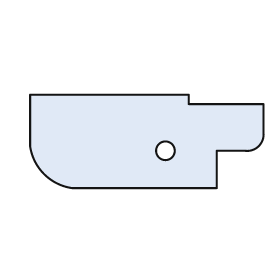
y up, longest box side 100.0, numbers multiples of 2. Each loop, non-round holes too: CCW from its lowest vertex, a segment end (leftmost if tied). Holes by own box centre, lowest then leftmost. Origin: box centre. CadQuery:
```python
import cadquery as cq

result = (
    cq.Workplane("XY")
    .moveTo(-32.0, -20.0)
    .lineTo(30.0, -20.0)
    .lineTo(30.0, -4.0)
    .lineTo(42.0, -4.0)
    .threePointArc((48.0, -2.0), (50.0, 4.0))
    .lineTo(50.0, 16.0)
    .lineTo(18.0, 16.0)
    .lineTo(18.0, 20.0)
    .lineTo(-50.0, 20.0)
    .lineTo(-50.0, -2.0)
    .threePointArc((-44.0, -14.0), (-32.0, -20.0))
    .close()
    .moveTo(8.0, -4.0)
    .circle(4.0)
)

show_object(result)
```